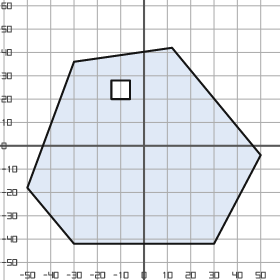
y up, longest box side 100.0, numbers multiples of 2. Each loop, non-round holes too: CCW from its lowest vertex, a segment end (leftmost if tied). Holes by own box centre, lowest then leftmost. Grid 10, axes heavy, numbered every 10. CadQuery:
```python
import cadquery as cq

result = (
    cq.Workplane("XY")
    .moveTo(-30.0, -42.0)
    .lineTo(30.0, -42.0)
    .lineTo(50.0, -4.0)
    .lineTo(12.0, 42.0)
    .lineTo(-30.0, 36.0)
    .lineTo(-50.0, -18.0)
    .close()
    .moveTo(-14.0, 20.0)
    .lineTo(-6.0, 20.0)
    .lineTo(-6.0, 28.0)
    .lineTo(-14.0, 28.0)
    .close()
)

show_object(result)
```